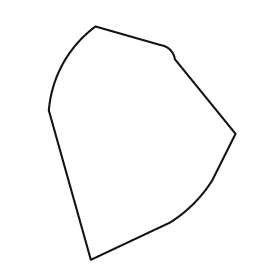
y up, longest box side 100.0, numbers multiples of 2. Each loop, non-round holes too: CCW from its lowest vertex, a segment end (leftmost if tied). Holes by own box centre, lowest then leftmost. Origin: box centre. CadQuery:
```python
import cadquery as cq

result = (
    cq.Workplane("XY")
    .moveTo(-22.0, -50.0)
    .lineTo(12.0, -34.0)
    .threePointArc((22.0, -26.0), (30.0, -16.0))
    .lineTo(40.0, 4.0)
    .lineTo(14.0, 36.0)
    .threePointArc((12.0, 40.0), (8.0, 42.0))
    .lineTo(-20.0, 50.0)
    .threePointArc((-34.0, 34.0), (-40.0, 14.0))
    .close()
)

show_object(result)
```